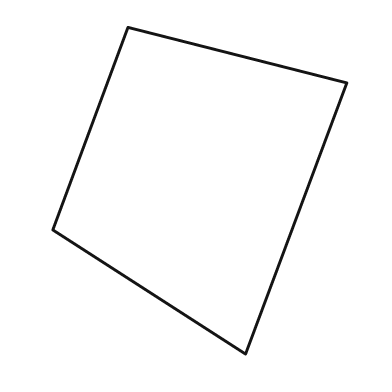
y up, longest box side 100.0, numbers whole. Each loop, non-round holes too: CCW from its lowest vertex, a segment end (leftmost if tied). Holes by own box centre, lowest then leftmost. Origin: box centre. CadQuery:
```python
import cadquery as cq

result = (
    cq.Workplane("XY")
    .moveTo(14.0, -50.0)
    .lineTo(45.0, 33.0)
    .lineTo(-22.0, 50.0)
    .lineTo(-45.0, -12.0)
    .close()
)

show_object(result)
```